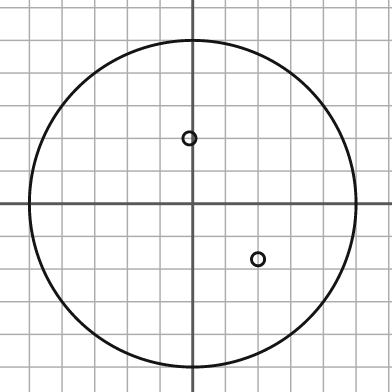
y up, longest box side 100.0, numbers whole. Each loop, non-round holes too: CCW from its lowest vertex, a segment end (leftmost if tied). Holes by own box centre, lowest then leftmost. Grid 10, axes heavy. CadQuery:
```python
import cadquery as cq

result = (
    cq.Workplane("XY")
    .moveTo(0.0, 0.0)
    .circle(50.0)
    .moveTo(20.0, -17.0)
    .circle(2.0)
    .moveTo(-1.0, 20.0)
    .circle(2.0)
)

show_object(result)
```